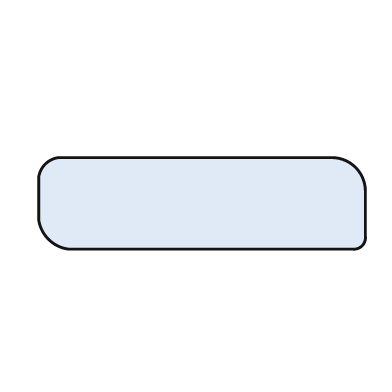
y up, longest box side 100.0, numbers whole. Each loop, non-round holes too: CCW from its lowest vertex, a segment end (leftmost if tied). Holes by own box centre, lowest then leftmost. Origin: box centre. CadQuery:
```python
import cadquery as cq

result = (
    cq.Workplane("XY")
    .moveTo(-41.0, -14.0)
    .lineTo(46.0, -14.0)
    .threePointArc((49.0, -13.0), (50.0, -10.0))
    .lineTo(50.0, 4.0)
    .threePointArc((47.0, 11.0), (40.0, 14.0))
    .lineTo(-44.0, 14.0)
    .threePointArc((-48.0, 12.0), (-50.0, 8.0))
    .lineTo(-50.0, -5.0)
    .threePointArc((-47.0, -11.0), (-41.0, -14.0))
    .close()
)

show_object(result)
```